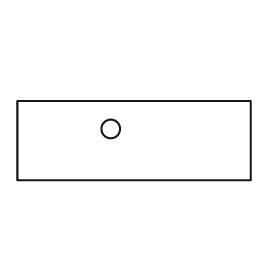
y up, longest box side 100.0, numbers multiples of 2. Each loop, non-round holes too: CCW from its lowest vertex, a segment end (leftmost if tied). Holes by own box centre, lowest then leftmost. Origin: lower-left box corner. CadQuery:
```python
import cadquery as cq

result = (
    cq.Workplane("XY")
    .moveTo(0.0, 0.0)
    .lineTo(100.0, 0.0)
    .lineTo(100.0, 34.0)
    .lineTo(0.0, 34.0)
    .close()
    .moveTo(40.0, 22.0)
    .circle(4.0)
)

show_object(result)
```